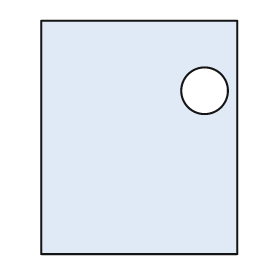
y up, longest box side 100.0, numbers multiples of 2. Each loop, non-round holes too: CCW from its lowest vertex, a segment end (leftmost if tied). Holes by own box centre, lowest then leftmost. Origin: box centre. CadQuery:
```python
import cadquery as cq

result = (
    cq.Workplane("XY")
    .moveTo(-42.0, -50.0)
    .lineTo(42.0, -50.0)
    .lineTo(42.0, 50.0)
    .lineTo(-42.0, 50.0)
    .close()
    .moveTo(28.0, 20.0)
    .circle(10.0)
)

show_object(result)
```